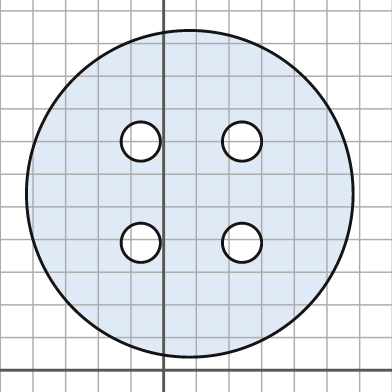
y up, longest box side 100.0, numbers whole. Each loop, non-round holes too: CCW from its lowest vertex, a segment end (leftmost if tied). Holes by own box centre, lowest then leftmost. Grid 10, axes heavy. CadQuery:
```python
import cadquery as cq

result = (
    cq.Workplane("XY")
    .moveTo(8.0, 54.0)
    .circle(50.0)
    .moveTo(-7.0, 39.0)
    .circle(6.0)
    .moveTo(24.0, 39.0)
    .circle(6.0)
    .moveTo(-7.0, 70.0)
    .circle(6.0)
    .moveTo(24.0, 70.0)
    .circle(6.0)
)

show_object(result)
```